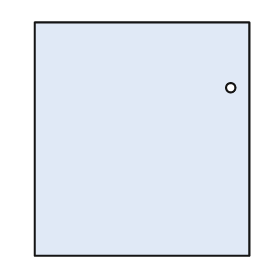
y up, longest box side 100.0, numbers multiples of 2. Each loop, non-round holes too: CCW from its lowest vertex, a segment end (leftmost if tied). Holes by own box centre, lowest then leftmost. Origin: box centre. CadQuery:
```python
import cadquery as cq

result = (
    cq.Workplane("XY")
    .moveTo(-46.0, -50.0)
    .lineTo(46.0, -50.0)
    .lineTo(46.0, 50.0)
    .lineTo(-46.0, 50.0)
    .close()
    .moveTo(38.0, 22.0)
    .circle(2.0)
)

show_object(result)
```